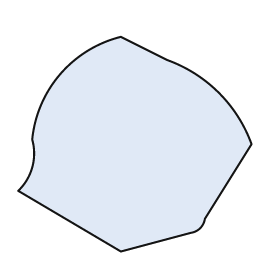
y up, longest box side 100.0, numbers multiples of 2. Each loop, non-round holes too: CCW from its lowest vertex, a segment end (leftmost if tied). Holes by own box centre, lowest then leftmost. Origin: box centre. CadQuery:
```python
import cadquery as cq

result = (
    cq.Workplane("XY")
    .moveTo(-6.0, -46.0)
    .lineTo(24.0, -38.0)
    .threePointArc((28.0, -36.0), (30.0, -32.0))
    .lineTo(50.0, 0.0)
    .threePointArc((36.0, 22.0), (14.0, 36.0))
    .lineTo(-6.0, 46.0)
    .threePointArc((-32.0, 30.0), (-44.0, 2.0))
    .threePointArc((-44.0, -10.0), (-50.0, -20.0))
    .close()
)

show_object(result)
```